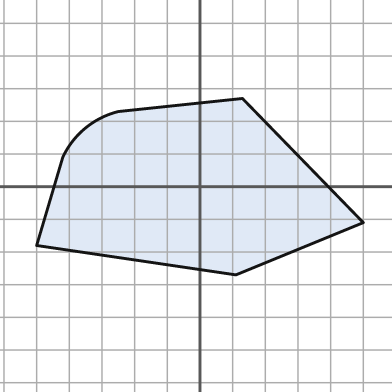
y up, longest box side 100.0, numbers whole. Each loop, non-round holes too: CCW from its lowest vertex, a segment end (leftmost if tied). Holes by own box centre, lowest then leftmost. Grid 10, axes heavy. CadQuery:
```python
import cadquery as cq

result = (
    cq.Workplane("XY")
    .moveTo(11.0, -27.0)
    .lineTo(50.0, -11.0)
    .lineTo(13.0, 27.0)
    .lineTo(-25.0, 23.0)
    .threePointArc((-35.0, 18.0), (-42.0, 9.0))
    .lineTo(-50.0, -18.0)
    .close()
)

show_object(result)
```